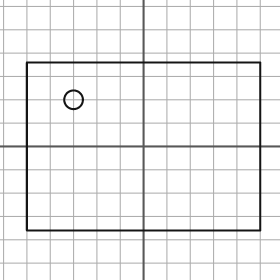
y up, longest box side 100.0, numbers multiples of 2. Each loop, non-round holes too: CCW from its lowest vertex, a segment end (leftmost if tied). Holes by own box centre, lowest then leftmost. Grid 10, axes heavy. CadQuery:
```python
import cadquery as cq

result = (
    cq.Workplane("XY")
    .moveTo(-50.0, -36.0)
    .lineTo(50.0, -36.0)
    .lineTo(50.0, 36.0)
    .lineTo(-50.0, 36.0)
    .close()
    .moveTo(-30.0, 20.0)
    .circle(4.0)
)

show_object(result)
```